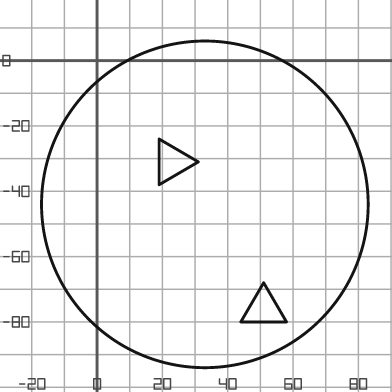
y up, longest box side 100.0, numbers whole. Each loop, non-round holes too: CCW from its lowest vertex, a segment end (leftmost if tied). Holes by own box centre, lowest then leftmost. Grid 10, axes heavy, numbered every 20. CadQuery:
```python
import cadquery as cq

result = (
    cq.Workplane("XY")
    .moveTo(33.0, -44.0)
    .circle(50.0)
    .moveTo(44.0, -80.0)
    .lineTo(58.0, -80.0)
    .lineTo(51.0, -68.0)
    .close()
    .moveTo(19.0, -38.0)
    .lineTo(31.0, -31.0)
    .lineTo(19.0, -24.0)
    .close()
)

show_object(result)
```